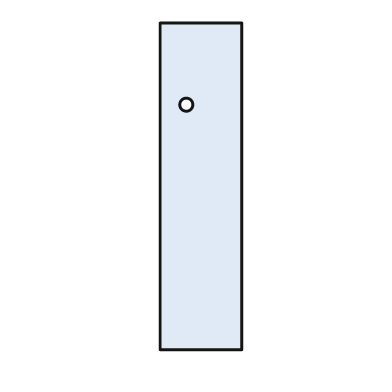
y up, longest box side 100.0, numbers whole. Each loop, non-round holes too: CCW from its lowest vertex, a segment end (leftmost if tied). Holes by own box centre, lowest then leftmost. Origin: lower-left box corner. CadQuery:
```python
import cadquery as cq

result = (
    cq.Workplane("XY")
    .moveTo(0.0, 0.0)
    .lineTo(25.0, 0.0)
    .lineTo(25.0, 100.0)
    .lineTo(0.0, 100.0)
    .close()
    .moveTo(8.0, 75.0)
    .circle(2.0)
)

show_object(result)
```